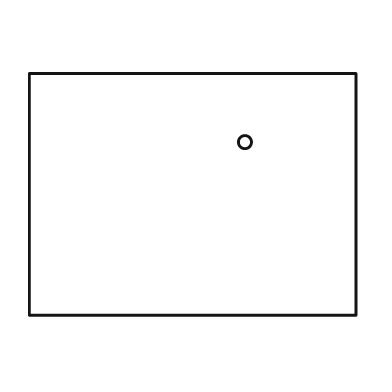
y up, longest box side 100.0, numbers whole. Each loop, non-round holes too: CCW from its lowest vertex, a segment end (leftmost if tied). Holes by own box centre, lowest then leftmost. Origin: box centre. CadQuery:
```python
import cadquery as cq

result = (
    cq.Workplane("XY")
    .moveTo(-50.0, -37.0)
    .lineTo(50.0, -37.0)
    .lineTo(50.0, 37.0)
    .lineTo(-50.0, 37.0)
    .close()
    .moveTo(16.0, 16.0)
    .circle(2.0)
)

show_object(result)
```